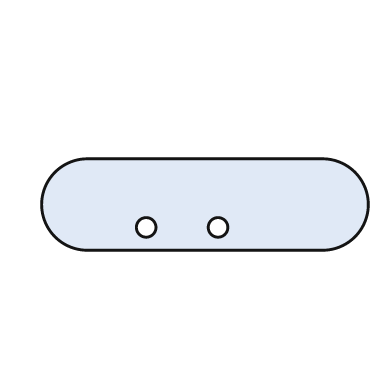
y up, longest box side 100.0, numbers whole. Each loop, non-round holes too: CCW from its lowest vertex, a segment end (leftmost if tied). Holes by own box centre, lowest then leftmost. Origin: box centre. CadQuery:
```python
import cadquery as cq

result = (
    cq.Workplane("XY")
    .moveTo(-36.0, -14.0)
    .lineTo(36.0, -14.0)
    .threePointArc((50.0, 0.0), (36.0, 14.0))
    .lineTo(-36.0, 14.0)
    .threePointArc((-50.0, 0.0), (-36.0, -14.0))
    .close()
    .moveTo(-18.0, -7.0)
    .circle(3.0)
    .moveTo(4.0, -7.0)
    .circle(3.0)
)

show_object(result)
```